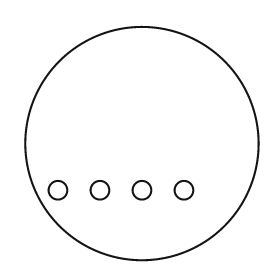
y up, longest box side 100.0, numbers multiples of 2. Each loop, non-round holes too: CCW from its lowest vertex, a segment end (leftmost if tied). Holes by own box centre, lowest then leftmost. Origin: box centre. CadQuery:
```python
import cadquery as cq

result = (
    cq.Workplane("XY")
    .moveTo(0.0, 0.0)
    .circle(50.0)
    .moveTo(-36.0, -20.0)
    .circle(4.0)
    .moveTo(-18.0, -20.0)
    .circle(4.0)
    .moveTo(0.0, -20.0)
    .circle(4.0)
    .moveTo(18.0, -20.0)
    .circle(4.0)
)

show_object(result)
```